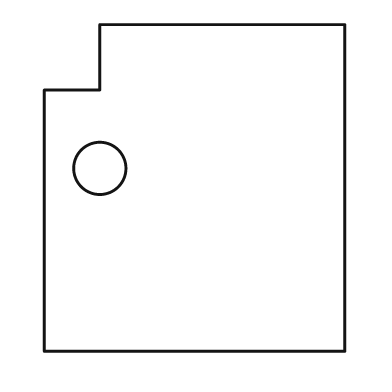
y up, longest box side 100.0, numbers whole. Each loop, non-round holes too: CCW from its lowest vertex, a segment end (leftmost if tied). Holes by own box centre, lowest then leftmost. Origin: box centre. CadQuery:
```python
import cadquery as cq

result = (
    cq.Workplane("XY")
    .moveTo(-46.0, -50.0)
    .lineTo(46.0, -50.0)
    .lineTo(46.0, 50.0)
    .lineTo(-29.0, 50.0)
    .lineTo(-29.0, 30.0)
    .lineTo(-46.0, 30.0)
    .close()
    .moveTo(-29.0, 6.0)
    .circle(8.0)
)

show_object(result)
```